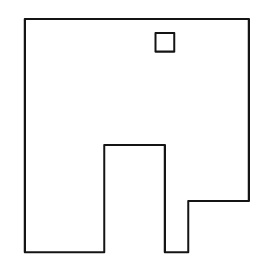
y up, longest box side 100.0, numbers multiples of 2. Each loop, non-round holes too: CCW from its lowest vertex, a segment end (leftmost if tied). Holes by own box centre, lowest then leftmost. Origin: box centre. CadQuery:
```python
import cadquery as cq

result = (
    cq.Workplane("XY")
    .moveTo(-48.0, -50.0)
    .lineTo(-14.0, -50.0)
    .lineTo(-14.0, -4.0)
    .lineTo(12.0, -4.0)
    .lineTo(12.0, -50.0)
    .lineTo(22.0, -50.0)
    .lineTo(22.0, -28.0)
    .lineTo(48.0, -28.0)
    .lineTo(48.0, 50.0)
    .lineTo(-48.0, 50.0)
    .close()
    .moveTo(8.0, 36.0)
    .lineTo(16.0, 36.0)
    .lineTo(16.0, 44.0)
    .lineTo(8.0, 44.0)
    .close()
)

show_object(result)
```